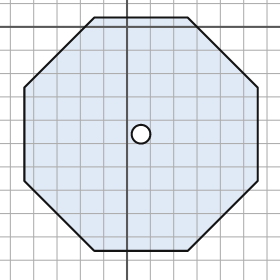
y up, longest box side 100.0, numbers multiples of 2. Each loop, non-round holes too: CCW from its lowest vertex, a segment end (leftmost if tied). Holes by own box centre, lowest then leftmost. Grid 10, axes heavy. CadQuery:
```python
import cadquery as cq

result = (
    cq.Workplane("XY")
    .moveTo(-14.0, -96.0)
    .lineTo(26.0, -96.0)
    .lineTo(56.0, -66.0)
    .lineTo(56.0, -26.0)
    .lineTo(26.0, 4.0)
    .lineTo(-14.0, 4.0)
    .lineTo(-44.0, -26.0)
    .lineTo(-44.0, -66.0)
    .close()
    .moveTo(6.0, -46.0)
    .circle(4.0)
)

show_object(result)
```